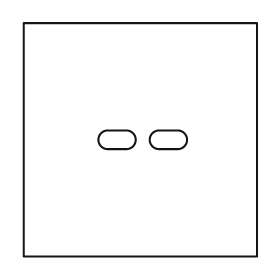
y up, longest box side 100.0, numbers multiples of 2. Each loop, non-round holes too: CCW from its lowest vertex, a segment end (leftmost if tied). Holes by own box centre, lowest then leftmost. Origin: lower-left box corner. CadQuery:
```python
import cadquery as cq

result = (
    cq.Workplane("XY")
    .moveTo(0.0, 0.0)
    .lineTo(100.0, 0.0)
    .lineTo(100.0, 100.0)
    .lineTo(0.0, 100.0)
    .close()
    .moveTo(36.0, 46.0)
    .lineTo(44.0, 46.0)
    .threePointArc((48.0, 50.0), (44.0, 54.0))
    .lineTo(36.0, 54.0)
    .threePointArc((32.0, 50.0), (36.0, 46.0))
    .close()
    .moveTo(58.0, 46.0)
    .lineTo(66.0, 46.0)
    .threePointArc((70.0, 50.0), (66.0, 54.0))
    .lineTo(58.0, 54.0)
    .threePointArc((54.0, 50.0), (58.0, 46.0))
    .close()
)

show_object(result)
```